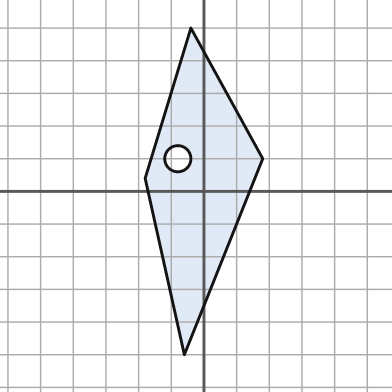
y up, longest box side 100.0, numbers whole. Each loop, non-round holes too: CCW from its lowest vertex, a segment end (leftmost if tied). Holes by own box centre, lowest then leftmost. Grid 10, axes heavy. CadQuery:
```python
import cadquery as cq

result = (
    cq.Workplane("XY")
    .moveTo(-6.0, -50.0)
    .lineTo(18.0, 10.0)
    .lineTo(-4.0, 50.0)
    .lineTo(-18.0, 4.0)
    .close()
    .moveTo(-8.0, 10.0)
    .circle(4.0)
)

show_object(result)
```